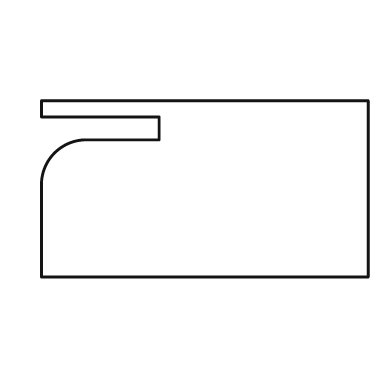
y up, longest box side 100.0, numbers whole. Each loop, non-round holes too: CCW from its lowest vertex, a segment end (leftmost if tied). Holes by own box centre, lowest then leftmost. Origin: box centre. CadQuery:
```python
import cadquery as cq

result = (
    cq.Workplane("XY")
    .moveTo(-50.0, -27.0)
    .lineTo(50.0, -27.0)
    .lineTo(50.0, 27.0)
    .lineTo(-50.0, 27.0)
    .lineTo(-50.0, 22.0)
    .lineTo(-14.0, 22.0)
    .lineTo(-14.0, 15.0)
    .lineTo(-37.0, 15.0)
    .threePointArc((-46.0, 11.0), (-50.0, 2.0))
    .close()
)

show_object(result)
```